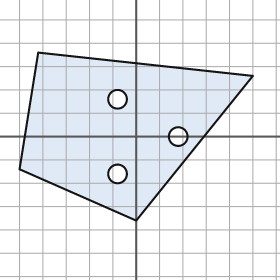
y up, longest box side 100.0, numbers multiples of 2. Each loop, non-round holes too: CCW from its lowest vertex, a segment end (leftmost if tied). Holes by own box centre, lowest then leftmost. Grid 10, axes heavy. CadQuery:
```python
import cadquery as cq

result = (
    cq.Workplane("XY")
    .moveTo(0.0, -36.0)
    .lineTo(50.0, 26.0)
    .lineTo(-42.0, 36.0)
    .lineTo(-50.0, -14.0)
    .close()
    .moveTo(-8.0, -16.0)
    .circle(4.0)
    .moveTo(18.0, 0.0)
    .circle(4.0)
    .moveTo(-8.0, 16.0)
    .circle(4.0)
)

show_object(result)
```